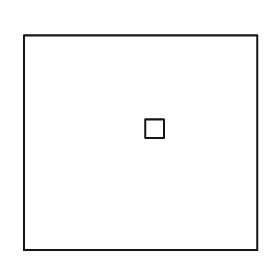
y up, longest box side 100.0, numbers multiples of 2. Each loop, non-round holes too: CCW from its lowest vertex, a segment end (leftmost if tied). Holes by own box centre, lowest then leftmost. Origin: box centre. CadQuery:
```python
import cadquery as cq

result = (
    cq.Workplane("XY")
    .moveTo(-50.0, -46.0)
    .lineTo(50.0, -46.0)
    .lineTo(50.0, 46.0)
    .lineTo(-50.0, 46.0)
    .close()
    .moveTo(2.0, 2.0)
    .lineTo(10.0, 2.0)
    .lineTo(10.0, 10.0)
    .lineTo(2.0, 10.0)
    .close()
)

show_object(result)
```